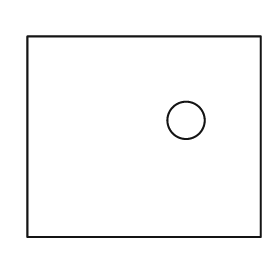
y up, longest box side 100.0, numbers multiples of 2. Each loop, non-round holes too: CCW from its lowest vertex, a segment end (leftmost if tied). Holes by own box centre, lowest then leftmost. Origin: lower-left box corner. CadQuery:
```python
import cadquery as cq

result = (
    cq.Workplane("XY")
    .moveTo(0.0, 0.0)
    .lineTo(100.0, 0.0)
    .lineTo(100.0, 86.0)
    .lineTo(0.0, 86.0)
    .close()
    .moveTo(68.0, 50.0)
    .circle(8.0)
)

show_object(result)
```